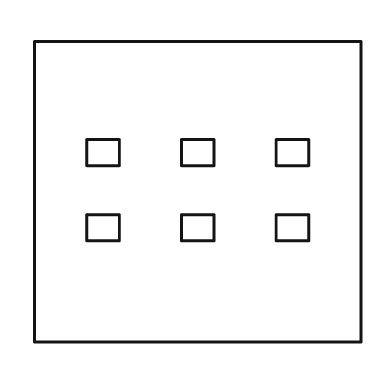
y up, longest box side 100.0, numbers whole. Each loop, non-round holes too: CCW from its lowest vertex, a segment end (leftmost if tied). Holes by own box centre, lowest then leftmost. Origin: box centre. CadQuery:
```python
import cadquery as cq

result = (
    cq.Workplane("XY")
    .moveTo(-50.0, -46.0)
    .lineTo(50.0, -46.0)
    .lineTo(50.0, 46.0)
    .lineTo(-50.0, 46.0)
    .close()
    .moveTo(-34.0, -15.0)
    .lineTo(-24.0, -15.0)
    .lineTo(-24.0, -7.0)
    .lineTo(-34.0, -7.0)
    .close()
    .moveTo(-5.0, -15.0)
    .lineTo(5.0, -15.0)
    .lineTo(5.0, -7.0)
    .lineTo(-5.0, -7.0)
    .close()
    .moveTo(24.0, -15.0)
    .lineTo(34.0, -15.0)
    .lineTo(34.0, -7.0)
    .lineTo(24.0, -7.0)
    .close()
    .moveTo(-34.0, 8.0)
    .lineTo(-24.0, 8.0)
    .lineTo(-24.0, 16.0)
    .lineTo(-34.0, 16.0)
    .close()
    .moveTo(-5.0, 8.0)
    .lineTo(5.0, 8.0)
    .lineTo(5.0, 16.0)
    .lineTo(-5.0, 16.0)
    .close()
    .moveTo(24.0, 8.0)
    .lineTo(34.0, 8.0)
    .lineTo(34.0, 16.0)
    .lineTo(24.0, 16.0)
    .close()
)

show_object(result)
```